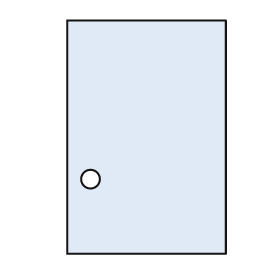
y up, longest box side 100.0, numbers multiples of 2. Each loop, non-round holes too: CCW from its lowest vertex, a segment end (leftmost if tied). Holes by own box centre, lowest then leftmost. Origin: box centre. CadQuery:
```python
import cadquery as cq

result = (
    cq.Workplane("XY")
    .moveTo(-34.0, -50.0)
    .lineTo(34.0, -50.0)
    .lineTo(34.0, 50.0)
    .lineTo(-34.0, 50.0)
    .close()
    .moveTo(-24.0, -18.0)
    .circle(4.0)
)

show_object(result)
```